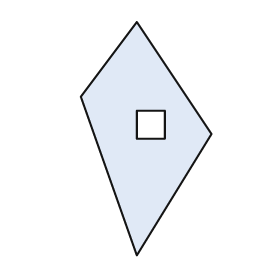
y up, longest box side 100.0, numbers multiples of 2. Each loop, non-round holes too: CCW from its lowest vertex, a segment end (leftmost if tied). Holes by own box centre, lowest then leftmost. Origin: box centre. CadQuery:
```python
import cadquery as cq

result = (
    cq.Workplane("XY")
    .moveTo(-4.0, -50.0)
    .lineTo(28.0, 2.0)
    .lineTo(-4.0, 50.0)
    .lineTo(-28.0, 18.0)
    .close()
    .moveTo(-4.0, 0.0)
    .lineTo(8.0, 0.0)
    .lineTo(8.0, 12.0)
    .lineTo(-4.0, 12.0)
    .close()
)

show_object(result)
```